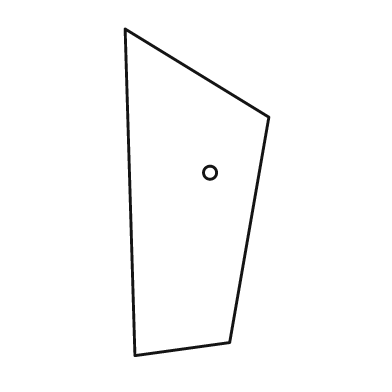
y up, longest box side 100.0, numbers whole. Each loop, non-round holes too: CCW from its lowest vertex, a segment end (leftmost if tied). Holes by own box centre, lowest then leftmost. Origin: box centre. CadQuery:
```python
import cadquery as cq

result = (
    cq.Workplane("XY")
    .moveTo(-19.0, -50.0)
    .lineTo(10.0, -46.0)
    .lineTo(22.0, 23.0)
    .lineTo(-22.0, 50.0)
    .close()
    .moveTo(4.0, 6.0)
    .circle(2.0)
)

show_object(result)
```